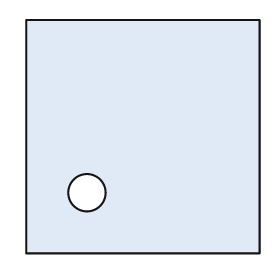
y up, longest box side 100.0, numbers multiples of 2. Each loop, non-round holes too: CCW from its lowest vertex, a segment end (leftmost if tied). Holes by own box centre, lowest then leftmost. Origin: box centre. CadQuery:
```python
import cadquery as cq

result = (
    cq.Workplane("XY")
    .moveTo(-50.0, -50.0)
    .lineTo(50.0, -50.0)
    .lineTo(50.0, 50.0)
    .lineTo(-50.0, 50.0)
    .close()
    .moveTo(-24.0, -24.0)
    .circle(8.0)
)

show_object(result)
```